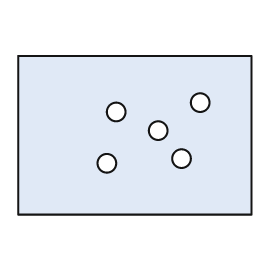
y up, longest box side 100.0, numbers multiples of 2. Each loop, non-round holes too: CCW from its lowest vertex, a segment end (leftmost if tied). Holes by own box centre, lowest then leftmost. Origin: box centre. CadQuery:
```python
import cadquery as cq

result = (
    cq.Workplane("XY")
    .moveTo(-50.0, -34.0)
    .lineTo(50.0, -34.0)
    .lineTo(50.0, 34.0)
    .lineTo(-50.0, 34.0)
    .close()
    .moveTo(-12.0, -12.0)
    .circle(4.0)
    .moveTo(20.0, -10.0)
    .circle(4.0)
    .moveTo(10.0, 2.0)
    .circle(4.0)
    .moveTo(-8.0, 10.0)
    .circle(4.0)
    .moveTo(28.0, 14.0)
    .circle(4.0)
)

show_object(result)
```